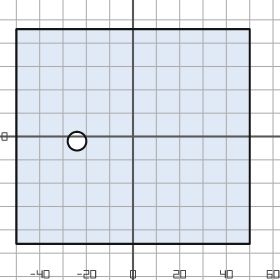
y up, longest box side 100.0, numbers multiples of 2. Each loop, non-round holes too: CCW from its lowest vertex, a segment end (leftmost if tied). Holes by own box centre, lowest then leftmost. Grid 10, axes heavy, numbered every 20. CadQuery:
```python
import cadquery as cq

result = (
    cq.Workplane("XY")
    .moveTo(-50.0, -46.0)
    .lineTo(50.0, -46.0)
    .lineTo(50.0, 46.0)
    .lineTo(-50.0, 46.0)
    .close()
    .moveTo(-24.0, -2.0)
    .circle(4.0)
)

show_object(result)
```